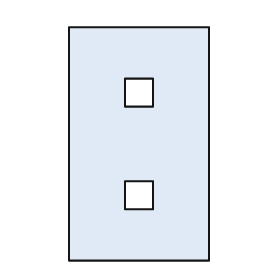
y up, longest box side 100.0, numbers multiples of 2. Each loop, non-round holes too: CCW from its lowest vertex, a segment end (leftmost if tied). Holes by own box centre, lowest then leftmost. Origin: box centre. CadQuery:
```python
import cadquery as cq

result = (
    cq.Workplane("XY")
    .moveTo(-30.0, -50.0)
    .lineTo(30.0, -50.0)
    .lineTo(30.0, 50.0)
    .lineTo(-30.0, 50.0)
    .close()
    .moveTo(-6.0, -28.0)
    .lineTo(6.0, -28.0)
    .lineTo(6.0, -16.0)
    .lineTo(-6.0, -16.0)
    .close()
    .moveTo(-6.0, 16.0)
    .lineTo(6.0, 16.0)
    .lineTo(6.0, 28.0)
    .lineTo(-6.0, 28.0)
    .close()
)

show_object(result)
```